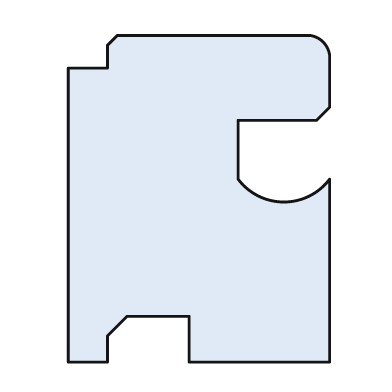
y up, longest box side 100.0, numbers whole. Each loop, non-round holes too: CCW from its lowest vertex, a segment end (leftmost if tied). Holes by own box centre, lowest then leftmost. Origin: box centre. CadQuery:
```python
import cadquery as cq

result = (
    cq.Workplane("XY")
    .moveTo(-40.0, -50.0)
    .lineTo(-28.0, -50.0)
    .lineTo(-28.0, -42.0)
    .lineTo(-22.0, -36.0)
    .lineTo(-3.0, -36.0)
    .lineTo(-3.0, -50.0)
    .lineTo(40.0, -50.0)
    .lineTo(40.0, 6.0)
    .threePointArc((26.0, -1.0), (12.0, 6.0))
    .lineTo(12.0, 24.0)
    .lineTo(36.0, 24.0)
    .lineTo(40.0, 28.0)
    .lineTo(40.0, 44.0)
    .threePointArc((38.0, 48.0), (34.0, 50.0))
    .lineTo(-25.0, 50.0)
    .lineTo(-28.0, 47.0)
    .lineTo(-28.0, 40.0)
    .lineTo(-40.0, 40.0)
    .close()
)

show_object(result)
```